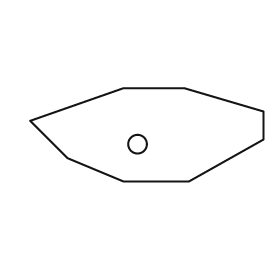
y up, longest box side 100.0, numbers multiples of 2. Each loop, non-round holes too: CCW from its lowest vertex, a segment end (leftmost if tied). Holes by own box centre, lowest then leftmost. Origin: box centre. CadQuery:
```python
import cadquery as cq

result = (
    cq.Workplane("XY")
    .moveTo(-10.0, -20.0)
    .lineTo(18.0, -20.0)
    .lineTo(50.0, -2.0)
    .lineTo(50.0, 10.0)
    .lineTo(16.0, 20.0)
    .lineTo(-10.0, 20.0)
    .lineTo(-50.0, 6.0)
    .lineTo(-34.0, -10.0)
    .close()
    .moveTo(-4.0, -4.0)
    .circle(4.0)
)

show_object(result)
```